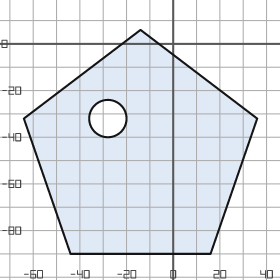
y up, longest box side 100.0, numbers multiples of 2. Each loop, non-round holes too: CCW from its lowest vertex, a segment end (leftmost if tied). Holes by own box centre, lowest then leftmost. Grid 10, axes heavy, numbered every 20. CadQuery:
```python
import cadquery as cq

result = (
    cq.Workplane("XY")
    .moveTo(-44.0, -90.0)
    .lineTo(16.0, -90.0)
    .lineTo(36.0, -32.0)
    .lineTo(-14.0, 6.0)
    .lineTo(-64.0, -32.0)
    .close()
    .moveTo(-28.0, -32.0)
    .circle(8.0)
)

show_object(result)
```